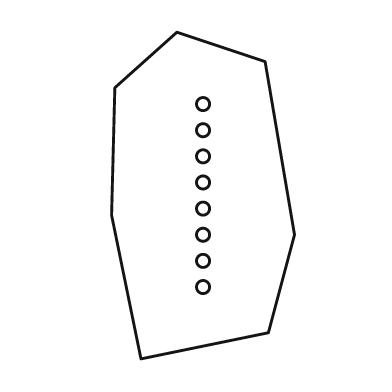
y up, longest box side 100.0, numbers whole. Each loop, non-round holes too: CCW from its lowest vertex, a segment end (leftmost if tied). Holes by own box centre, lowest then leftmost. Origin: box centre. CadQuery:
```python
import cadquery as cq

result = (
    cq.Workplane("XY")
    .moveTo(-19.0, -50.0)
    .lineTo(20.0, -42.0)
    .lineTo(28.0, -12.0)
    .lineTo(19.0, 41.0)
    .lineTo(-8.0, 50.0)
    .lineTo(-27.0, 33.0)
    .lineTo(-28.0, -6.0)
    .close()
    .moveTo(0.0, -28.0)
    .circle(2.0)
    .moveTo(0.0, -20.0)
    .circle(2.0)
    .moveTo(0.0, -12.0)
    .circle(2.0)
    .moveTo(0.0, -4.0)
    .circle(2.0)
    .moveTo(0.0, 4.0)
    .circle(2.0)
    .moveTo(0.0, 12.0)
    .circle(2.0)
    .moveTo(0.0, 20.0)
    .circle(2.0)
    .moveTo(0.0, 28.0)
    .circle(2.0)
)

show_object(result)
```